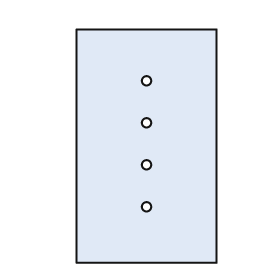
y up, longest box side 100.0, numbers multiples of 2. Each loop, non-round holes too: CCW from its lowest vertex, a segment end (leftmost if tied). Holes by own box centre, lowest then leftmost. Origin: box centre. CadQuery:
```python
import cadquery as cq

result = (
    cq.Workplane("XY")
    .moveTo(-30.0, -50.0)
    .lineTo(30.0, -50.0)
    .lineTo(30.0, 50.0)
    .lineTo(-30.0, 50.0)
    .close()
    .moveTo(0.0, -26.0)
    .circle(2.0)
    .moveTo(0.0, -8.0)
    .circle(2.0)
    .moveTo(0.0, 10.0)
    .circle(2.0)
    .moveTo(0.0, 28.0)
    .circle(2.0)
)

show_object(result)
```